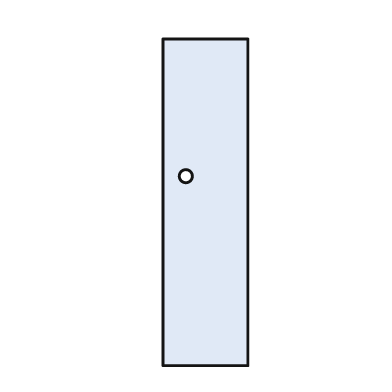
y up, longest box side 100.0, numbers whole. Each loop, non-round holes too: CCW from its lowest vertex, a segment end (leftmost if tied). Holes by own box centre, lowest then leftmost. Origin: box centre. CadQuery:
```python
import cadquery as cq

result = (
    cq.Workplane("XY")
    .moveTo(-13.0, -50.0)
    .lineTo(13.0, -50.0)
    .lineTo(13.0, 50.0)
    .lineTo(-13.0, 50.0)
    .close()
    .moveTo(-6.0, 8.0)
    .circle(2.0)
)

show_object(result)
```